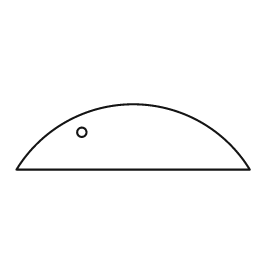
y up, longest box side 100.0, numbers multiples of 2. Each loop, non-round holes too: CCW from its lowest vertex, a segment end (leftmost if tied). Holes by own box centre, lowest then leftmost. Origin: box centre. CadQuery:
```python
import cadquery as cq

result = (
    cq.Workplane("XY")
    .moveTo(-50.0, -14.0)
    .lineTo(50.0, -14.0)
    .threePointArc((0.0, 14.0), (-50.0, -14.0))
    .close()
    .moveTo(-22.0, 2.0)
    .circle(2.0)
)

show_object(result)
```